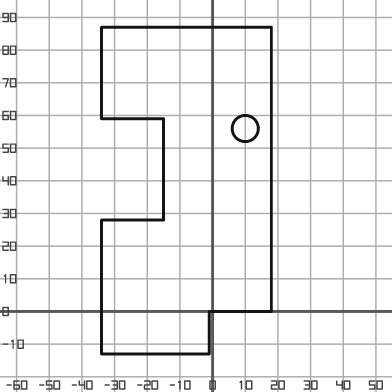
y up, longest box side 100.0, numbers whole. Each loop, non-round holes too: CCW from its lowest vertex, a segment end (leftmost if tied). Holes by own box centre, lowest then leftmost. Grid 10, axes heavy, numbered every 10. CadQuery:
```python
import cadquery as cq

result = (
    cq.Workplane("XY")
    .moveTo(-34.0, -13.0)
    .lineTo(-1.0, -13.0)
    .lineTo(-1.0, 0.0)
    .lineTo(18.0, 0.0)
    .lineTo(18.0, 87.0)
    .lineTo(-34.0, 87.0)
    .lineTo(-34.0, 59.0)
    .lineTo(-15.0, 59.0)
    .lineTo(-15.0, 28.0)
    .lineTo(-34.0, 28.0)
    .close()
    .moveTo(10.0, 56.0)
    .circle(4.0)
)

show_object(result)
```